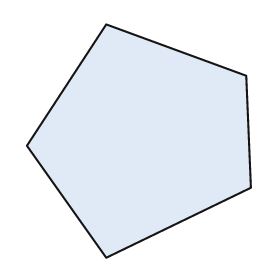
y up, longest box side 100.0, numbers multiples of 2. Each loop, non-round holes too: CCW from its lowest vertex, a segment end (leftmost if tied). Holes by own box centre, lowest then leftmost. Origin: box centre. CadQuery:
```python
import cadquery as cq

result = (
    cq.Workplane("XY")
    .moveTo(-14.0, -50.0)
    .lineTo(48.0, -20.0)
    .lineTo(46.0, 28.0)
    .lineTo(-14.0, 50.0)
    .lineTo(-48.0, -2.0)
    .close()
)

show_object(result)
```